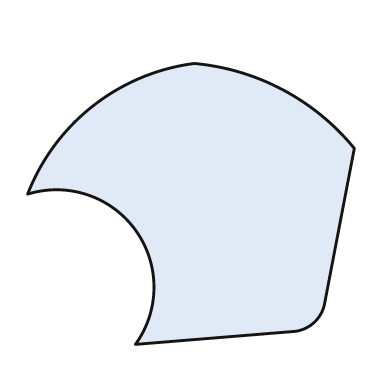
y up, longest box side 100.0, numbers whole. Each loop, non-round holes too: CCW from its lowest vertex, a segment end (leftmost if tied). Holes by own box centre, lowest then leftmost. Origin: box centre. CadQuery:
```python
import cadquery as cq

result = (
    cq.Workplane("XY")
    .moveTo(-17.0, -43.0)
    .lineTo(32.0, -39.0)
    .threePointArc((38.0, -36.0), (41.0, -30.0))
    .lineTo(50.0, 17.0)
    .threePointArc((28.0, 35.0), (1.0, 43.0))
    .threePointArc((-30.0, 30.0), (-50.0, 3.0))
    .threePointArc((-17.0, -8.0), (-17.0, -43.0))
    .close()
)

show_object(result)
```